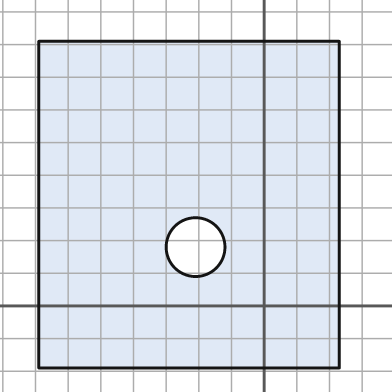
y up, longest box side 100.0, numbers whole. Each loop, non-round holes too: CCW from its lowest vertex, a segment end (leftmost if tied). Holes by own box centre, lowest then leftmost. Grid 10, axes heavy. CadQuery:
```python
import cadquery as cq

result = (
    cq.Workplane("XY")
    .moveTo(-69.0, -19.0)
    .lineTo(23.0, -19.0)
    .lineTo(23.0, 81.0)
    .lineTo(-69.0, 81.0)
    .close()
    .moveTo(-21.0, 18.0)
    .circle(9.0)
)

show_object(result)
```